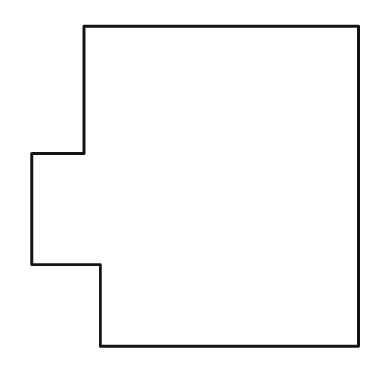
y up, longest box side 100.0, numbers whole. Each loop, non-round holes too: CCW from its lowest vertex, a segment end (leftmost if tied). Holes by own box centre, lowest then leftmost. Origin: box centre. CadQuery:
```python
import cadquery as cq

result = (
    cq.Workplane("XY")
    .moveTo(-29.0, -49.0)
    .lineTo(50.0, -49.0)
    .lineTo(50.0, 49.0)
    .lineTo(-34.0, 49.0)
    .lineTo(-34.0, 10.0)
    .lineTo(-50.0, 10.0)
    .lineTo(-50.0, -24.0)
    .lineTo(-29.0, -24.0)
    .close()
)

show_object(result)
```